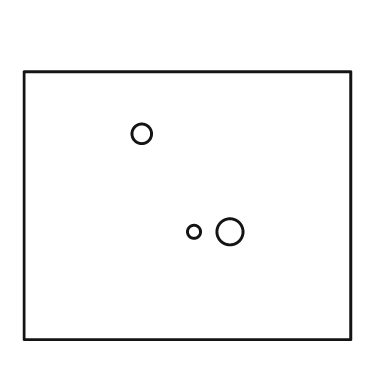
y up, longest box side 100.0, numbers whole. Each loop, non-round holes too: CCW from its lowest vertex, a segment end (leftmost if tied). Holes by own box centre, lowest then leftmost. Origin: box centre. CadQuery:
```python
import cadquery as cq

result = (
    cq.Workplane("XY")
    .moveTo(-50.0, -41.0)
    .lineTo(50.0, -41.0)
    .lineTo(50.0, 41.0)
    .lineTo(-50.0, 41.0)
    .close()
    .moveTo(2.0, -8.0)
    .circle(2.0)
    .moveTo(13.0, -8.0)
    .circle(4.0)
    .moveTo(-14.0, 22.0)
    .circle(3.0)
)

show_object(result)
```